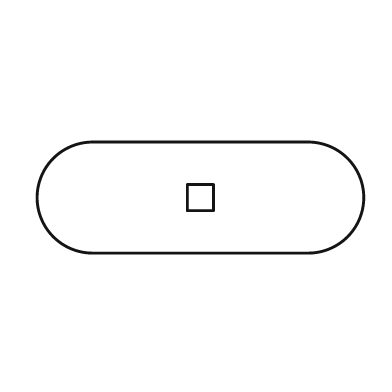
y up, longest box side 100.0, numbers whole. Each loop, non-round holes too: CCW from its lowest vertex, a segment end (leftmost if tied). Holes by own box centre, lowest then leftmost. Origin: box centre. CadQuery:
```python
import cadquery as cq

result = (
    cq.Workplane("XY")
    .moveTo(-33.0, -17.0)
    .lineTo(33.0, -17.0)
    .threePointArc((50.0, 0.0), (33.0, 17.0))
    .lineTo(-33.0, 17.0)
    .threePointArc((-50.0, 0.0), (-33.0, -17.0))
    .close()
    .moveTo(-4.0, -4.0)
    .lineTo(4.0, -4.0)
    .lineTo(4.0, 4.0)
    .lineTo(-4.0, 4.0)
    .close()
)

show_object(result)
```